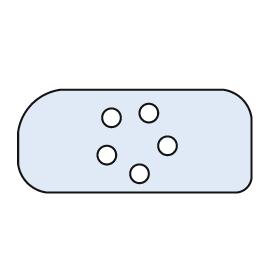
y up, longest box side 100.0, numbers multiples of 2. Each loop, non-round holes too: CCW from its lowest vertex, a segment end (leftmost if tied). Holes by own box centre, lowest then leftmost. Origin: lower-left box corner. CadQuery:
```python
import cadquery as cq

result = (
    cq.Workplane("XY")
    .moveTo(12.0, 0.0)
    .lineTo(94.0, 0.0)
    .threePointArc((98.0, 2.0), (100.0, 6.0))
    .lineTo(100.0, 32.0)
    .threePointArc((96.0, 40.0), (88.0, 44.0))
    .lineTo(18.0, 44.0)
    .threePointArc((6.0, 38.0), (0.0, 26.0))
    .lineTo(0.0, 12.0)
    .threePointArc((4.0, 4.0), (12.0, 0.0))
    .close()
    .moveTo(52.0, 8.0)
    .circle(4.0)
    .moveTo(38.0, 16.0)
    .circle(4.0)
    .moveTo(64.0, 20.0)
    .circle(4.0)
    .moveTo(40.0, 32.0)
    .circle(4.0)
    .moveTo(56.0, 34.0)
    .circle(4.0)
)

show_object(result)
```